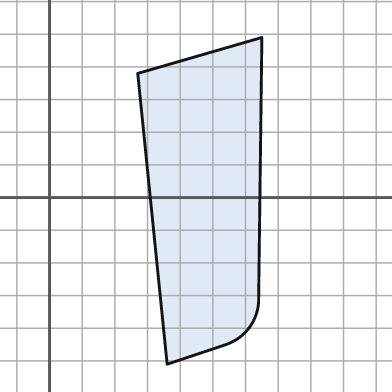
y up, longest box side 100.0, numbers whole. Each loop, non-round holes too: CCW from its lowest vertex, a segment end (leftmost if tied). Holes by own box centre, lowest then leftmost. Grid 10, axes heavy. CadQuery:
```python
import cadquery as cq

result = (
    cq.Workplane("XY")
    .moveTo(36.0, -51.0)
    .lineTo(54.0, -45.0)
    .threePointArc((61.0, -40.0), (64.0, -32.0))
    .lineTo(65.0, 49.0)
    .lineTo(27.0, 38.0)
    .close()
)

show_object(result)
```